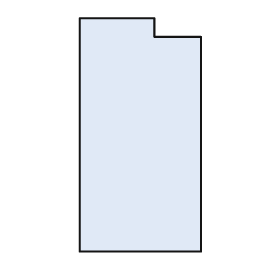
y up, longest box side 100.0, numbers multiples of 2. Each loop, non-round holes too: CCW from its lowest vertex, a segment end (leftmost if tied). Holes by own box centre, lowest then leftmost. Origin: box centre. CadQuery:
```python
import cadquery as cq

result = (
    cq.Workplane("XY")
    .moveTo(-26.0, -50.0)
    .lineTo(26.0, -50.0)
    .lineTo(26.0, 42.0)
    .lineTo(6.0, 42.0)
    .lineTo(6.0, 50.0)
    .lineTo(-26.0, 50.0)
    .close()
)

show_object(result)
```